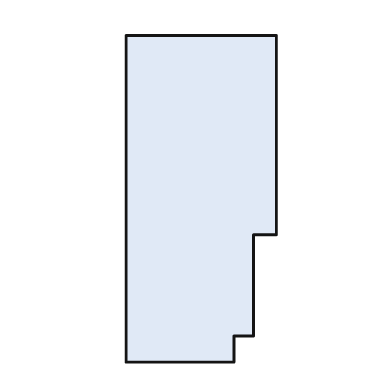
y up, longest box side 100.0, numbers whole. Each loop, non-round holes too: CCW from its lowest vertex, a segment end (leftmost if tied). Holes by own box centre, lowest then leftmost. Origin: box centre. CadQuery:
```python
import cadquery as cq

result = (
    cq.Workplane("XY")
    .moveTo(-23.0, -50.0)
    .lineTo(10.0, -50.0)
    .lineTo(10.0, -42.0)
    .lineTo(16.0, -42.0)
    .lineTo(16.0, -11.0)
    .lineTo(23.0, -11.0)
    .lineTo(23.0, 50.0)
    .lineTo(-23.0, 50.0)
    .close()
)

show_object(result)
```